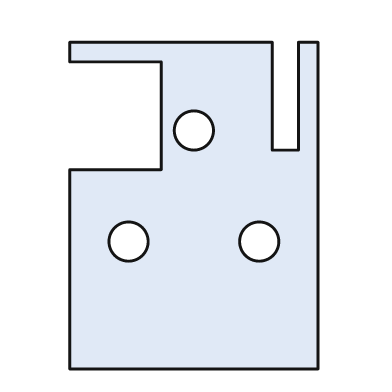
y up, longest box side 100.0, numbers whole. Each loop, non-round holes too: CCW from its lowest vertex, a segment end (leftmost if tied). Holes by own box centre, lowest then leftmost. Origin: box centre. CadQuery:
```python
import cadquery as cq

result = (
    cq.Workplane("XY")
    .moveTo(-38.0, -50.0)
    .lineTo(38.0, -50.0)
    .lineTo(38.0, 50.0)
    .lineTo(32.0, 50.0)
    .lineTo(32.0, 17.0)
    .lineTo(24.0, 17.0)
    .lineTo(24.0, 50.0)
    .lineTo(-38.0, 50.0)
    .lineTo(-38.0, 44.0)
    .lineTo(-10.0, 44.0)
    .lineTo(-10.0, 11.0)
    .lineTo(-38.0, 11.0)
    .close()
    .moveTo(-20.0, -11.0)
    .circle(6.0)
    .moveTo(20.0, -11.0)
    .circle(6.0)
    .moveTo(0.0, 23.0)
    .circle(6.0)
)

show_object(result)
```